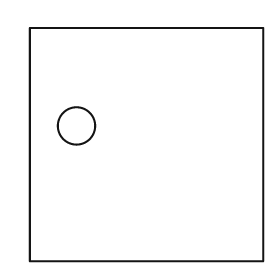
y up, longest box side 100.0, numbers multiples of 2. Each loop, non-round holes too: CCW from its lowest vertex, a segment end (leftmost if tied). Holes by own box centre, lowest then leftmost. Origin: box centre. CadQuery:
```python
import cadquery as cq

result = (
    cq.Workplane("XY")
    .moveTo(-50.0, -50.0)
    .lineTo(50.0, -50.0)
    .lineTo(50.0, 50.0)
    .lineTo(-50.0, 50.0)
    .close()
    .moveTo(-30.0, 8.0)
    .circle(8.0)
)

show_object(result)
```